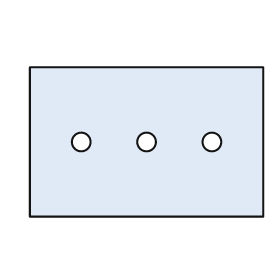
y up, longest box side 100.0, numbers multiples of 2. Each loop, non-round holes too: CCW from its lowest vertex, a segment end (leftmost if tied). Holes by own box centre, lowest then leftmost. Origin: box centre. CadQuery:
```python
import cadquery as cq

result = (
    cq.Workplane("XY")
    .moveTo(-50.0, -32.0)
    .lineTo(50.0, -32.0)
    .lineTo(50.0, 32.0)
    .lineTo(-50.0, 32.0)
    .close()
    .moveTo(-28.0, 0.0)
    .circle(4.0)
    .moveTo(0.0, 0.0)
    .circle(4.0)
    .moveTo(28.0, 0.0)
    .circle(4.0)
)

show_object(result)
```